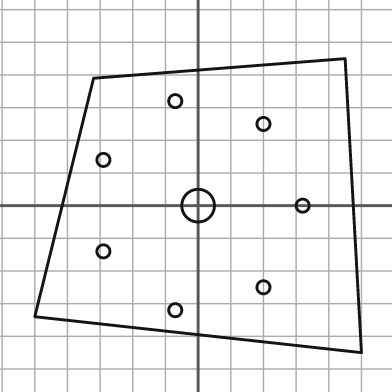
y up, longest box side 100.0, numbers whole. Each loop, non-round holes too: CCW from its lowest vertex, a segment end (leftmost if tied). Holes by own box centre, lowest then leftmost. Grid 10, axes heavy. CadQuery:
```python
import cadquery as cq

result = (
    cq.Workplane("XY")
    .moveTo(50.0, -45.0)
    .lineTo(45.0, 45.0)
    .lineTo(-32.0, 39.0)
    .lineTo(-50.0, -34.0)
    .close()
    .moveTo(-7.0, -32.0)
    .circle(2.0)
    .moveTo(20.0, -25.0)
    .circle(2.0)
    .moveTo(-29.0, -14.0)
    .circle(2.0)
    .moveTo(0.0, 0.0)
    .circle(5.0)
    .moveTo(32.0, 0.0)
    .circle(2.0)
    .moveTo(-29.0, 14.0)
    .circle(2.0)
    .moveTo(20.0, 25.0)
    .circle(2.0)
    .moveTo(-7.0, 32.0)
    .circle(2.0)
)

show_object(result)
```